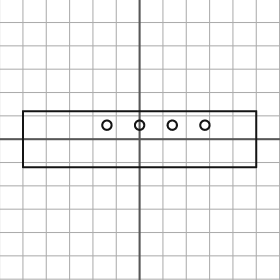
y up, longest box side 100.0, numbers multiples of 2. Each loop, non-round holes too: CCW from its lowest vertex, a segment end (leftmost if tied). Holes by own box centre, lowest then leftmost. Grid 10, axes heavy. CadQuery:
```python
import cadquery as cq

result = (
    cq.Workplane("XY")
    .moveTo(-50.0, -12.0)
    .lineTo(50.0, -12.0)
    .lineTo(50.0, 12.0)
    .lineTo(-50.0, 12.0)
    .close()
    .moveTo(-14.0, 6.0)
    .circle(2.0)
    .moveTo(0.0, 6.0)
    .circle(2.0)
    .moveTo(14.0, 6.0)
    .circle(2.0)
    .moveTo(28.0, 6.0)
    .circle(2.0)
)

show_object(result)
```